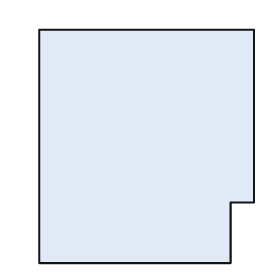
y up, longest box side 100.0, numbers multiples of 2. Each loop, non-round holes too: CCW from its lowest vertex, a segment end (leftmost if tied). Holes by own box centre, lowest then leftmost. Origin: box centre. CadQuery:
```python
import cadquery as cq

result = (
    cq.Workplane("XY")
    .moveTo(-46.0, -50.0)
    .lineTo(36.0, -50.0)
    .lineTo(36.0, -24.0)
    .lineTo(46.0, -24.0)
    .lineTo(46.0, 50.0)
    .lineTo(-46.0, 50.0)
    .close()
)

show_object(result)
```